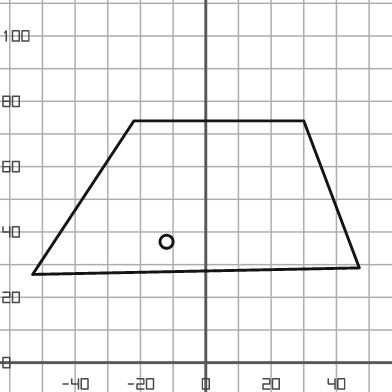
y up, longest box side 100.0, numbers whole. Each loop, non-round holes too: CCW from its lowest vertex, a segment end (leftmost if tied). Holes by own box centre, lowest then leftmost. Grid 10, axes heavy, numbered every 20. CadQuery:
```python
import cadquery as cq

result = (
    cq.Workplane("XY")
    .moveTo(-53.0, 27.0)
    .lineTo(47.0, 29.0)
    .lineTo(30.0, 74.0)
    .lineTo(-22.0, 74.0)
    .close()
    .moveTo(-12.0, 37.0)
    .circle(2.0)
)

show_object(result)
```